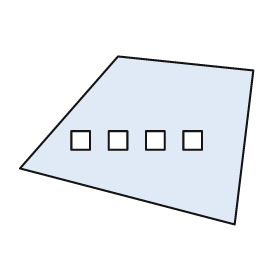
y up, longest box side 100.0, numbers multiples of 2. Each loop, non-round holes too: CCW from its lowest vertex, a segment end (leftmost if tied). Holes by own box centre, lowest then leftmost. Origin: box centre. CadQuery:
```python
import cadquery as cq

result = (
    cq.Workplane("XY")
    .moveTo(42.0, -36.0)
    .lineTo(50.0, 30.0)
    .lineTo(-8.0, 36.0)
    .lineTo(-50.0, -12.0)
    .close()
    .moveTo(-28.0, -4.0)
    .lineTo(-20.0, -4.0)
    .lineTo(-20.0, 4.0)
    .lineTo(-28.0, 4.0)
    .close()
    .moveTo(-12.0, -4.0)
    .lineTo(-4.0, -4.0)
    .lineTo(-4.0, 4.0)
    .lineTo(-12.0, 4.0)
    .close()
    .moveTo(4.0, -4.0)
    .lineTo(12.0, -4.0)
    .lineTo(12.0, 4.0)
    .lineTo(4.0, 4.0)
    .close()
    .moveTo(20.0, -4.0)
    .lineTo(28.0, -4.0)
    .lineTo(28.0, 4.0)
    .lineTo(20.0, 4.0)
    .close()
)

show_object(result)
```